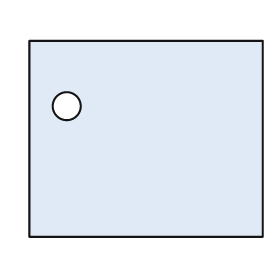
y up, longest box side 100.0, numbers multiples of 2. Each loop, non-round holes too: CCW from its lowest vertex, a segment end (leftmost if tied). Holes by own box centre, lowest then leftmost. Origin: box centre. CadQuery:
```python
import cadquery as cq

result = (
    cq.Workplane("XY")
    .moveTo(-50.0, -42.0)
    .lineTo(50.0, -42.0)
    .lineTo(50.0, 42.0)
    .lineTo(-50.0, 42.0)
    .close()
    .moveTo(-34.0, 14.0)
    .circle(6.0)
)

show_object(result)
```